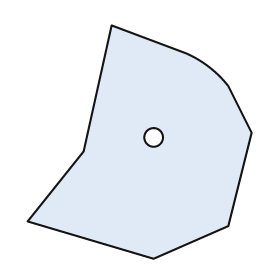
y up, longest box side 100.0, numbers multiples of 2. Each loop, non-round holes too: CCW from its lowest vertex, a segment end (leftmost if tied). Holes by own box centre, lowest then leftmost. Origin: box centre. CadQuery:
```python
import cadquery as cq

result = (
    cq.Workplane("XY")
    .moveTo(6.0, -50.0)
    .lineTo(38.0, -36.0)
    .lineTo(48.0, 4.0)
    .lineTo(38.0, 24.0)
    .threePointArc((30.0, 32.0), (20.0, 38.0))
    .lineTo(-12.0, 50.0)
    .lineTo(-24.0, -4.0)
    .lineTo(-48.0, -34.0)
    .close()
    .moveTo(6.0, 2.0)
    .circle(4.0)
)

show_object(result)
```